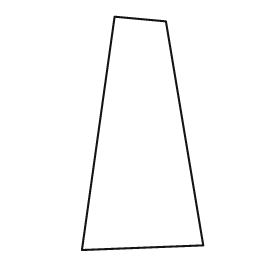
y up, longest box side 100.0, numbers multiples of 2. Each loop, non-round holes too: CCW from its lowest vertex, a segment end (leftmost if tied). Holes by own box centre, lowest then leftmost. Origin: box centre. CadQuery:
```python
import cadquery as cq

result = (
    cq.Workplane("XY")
    .moveTo(-26.0, -50.0)
    .lineTo(26.0, -48.0)
    .lineTo(10.0, 48.0)
    .lineTo(-12.0, 50.0)
    .close()
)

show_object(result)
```